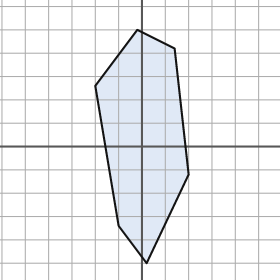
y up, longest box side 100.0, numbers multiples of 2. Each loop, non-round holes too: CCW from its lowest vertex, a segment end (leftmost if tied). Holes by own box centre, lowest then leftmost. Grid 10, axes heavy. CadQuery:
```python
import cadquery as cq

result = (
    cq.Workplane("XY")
    .moveTo(2.0, -50.0)
    .lineTo(20.0, -12.0)
    .lineTo(14.0, 42.0)
    .lineTo(-2.0, 50.0)
    .lineTo(-20.0, 26.0)
    .lineTo(-10.0, -34.0)
    .close()
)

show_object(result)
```